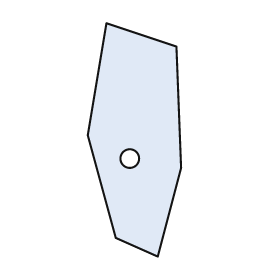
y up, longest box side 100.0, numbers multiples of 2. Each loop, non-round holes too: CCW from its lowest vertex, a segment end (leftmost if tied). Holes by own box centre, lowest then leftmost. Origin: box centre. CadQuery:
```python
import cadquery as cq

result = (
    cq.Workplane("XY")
    .moveTo(10.0, -50.0)
    .lineTo(20.0, -12.0)
    .lineTo(18.0, 40.0)
    .lineTo(-12.0, 50.0)
    .lineTo(-20.0, 2.0)
    .lineTo(-8.0, -42.0)
    .close()
    .moveTo(-2.0, -8.0)
    .circle(4.0)
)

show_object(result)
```